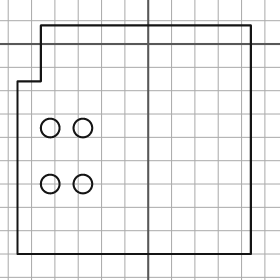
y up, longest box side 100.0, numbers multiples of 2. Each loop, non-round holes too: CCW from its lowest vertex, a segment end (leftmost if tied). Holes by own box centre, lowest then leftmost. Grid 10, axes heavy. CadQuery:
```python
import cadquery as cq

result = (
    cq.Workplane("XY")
    .moveTo(-56.0, -90.0)
    .lineTo(44.0, -90.0)
    .lineTo(44.0, 8.0)
    .lineTo(-46.0, 8.0)
    .lineTo(-46.0, -16.0)
    .lineTo(-56.0, -16.0)
    .close()
    .moveTo(-42.0, -60.0)
    .circle(4.0)
    .moveTo(-28.0, -60.0)
    .circle(4.0)
    .moveTo(-42.0, -36.0)
    .circle(4.0)
    .moveTo(-28.0, -36.0)
    .circle(4.0)
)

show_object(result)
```